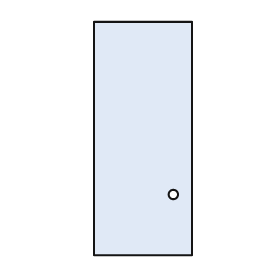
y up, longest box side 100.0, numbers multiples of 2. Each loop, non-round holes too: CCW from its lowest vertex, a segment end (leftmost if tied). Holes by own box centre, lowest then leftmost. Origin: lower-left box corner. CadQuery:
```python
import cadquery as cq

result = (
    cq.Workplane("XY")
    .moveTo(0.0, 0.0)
    .lineTo(42.0, 0.0)
    .lineTo(42.0, 100.0)
    .lineTo(0.0, 100.0)
    .close()
    .moveTo(34.0, 26.0)
    .circle(2.0)
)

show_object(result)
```